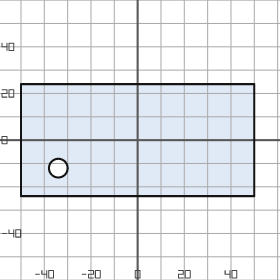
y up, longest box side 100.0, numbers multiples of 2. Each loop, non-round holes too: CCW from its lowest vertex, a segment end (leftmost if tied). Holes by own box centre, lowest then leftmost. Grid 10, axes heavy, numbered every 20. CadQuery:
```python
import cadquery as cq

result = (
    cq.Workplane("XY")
    .moveTo(-50.0, -24.0)
    .lineTo(50.0, -24.0)
    .lineTo(50.0, 24.0)
    .lineTo(-50.0, 24.0)
    .close()
    .moveTo(-34.0, -12.0)
    .circle(4.0)
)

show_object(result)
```